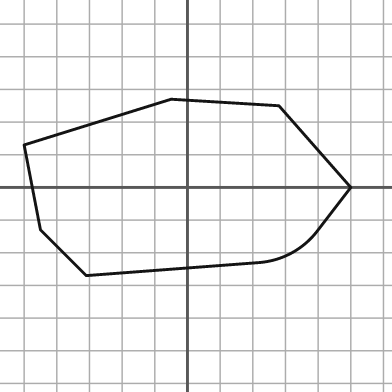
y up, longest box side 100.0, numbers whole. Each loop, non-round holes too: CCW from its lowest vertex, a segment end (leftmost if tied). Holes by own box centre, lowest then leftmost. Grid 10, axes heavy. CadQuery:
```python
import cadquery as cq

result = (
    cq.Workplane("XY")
    .moveTo(-31.0, -27.0)
    .lineTo(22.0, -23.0)
    .threePointArc((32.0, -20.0), (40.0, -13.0))
    .lineTo(50.0, 0.0)
    .lineTo(28.0, 25.0)
    .lineTo(-5.0, 27.0)
    .lineTo(-50.0, 13.0)
    .lineTo(-45.0, -13.0)
    .close()
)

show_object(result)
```